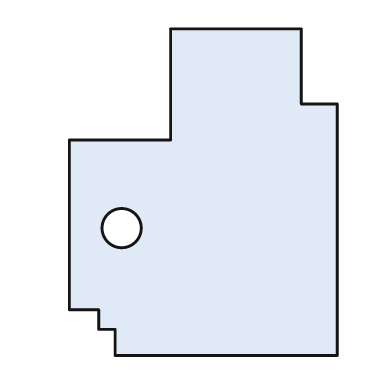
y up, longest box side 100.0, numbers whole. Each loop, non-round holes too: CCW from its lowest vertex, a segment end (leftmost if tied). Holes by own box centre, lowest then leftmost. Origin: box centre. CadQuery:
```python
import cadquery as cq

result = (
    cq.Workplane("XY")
    .moveTo(-27.0, -50.0)
    .lineTo(41.0, -50.0)
    .lineTo(41.0, 27.0)
    .lineTo(30.0, 27.0)
    .lineTo(30.0, 50.0)
    .lineTo(-10.0, 50.0)
    .lineTo(-10.0, 16.0)
    .lineTo(-41.0, 16.0)
    .lineTo(-41.0, -36.0)
    .lineTo(-32.0, -36.0)
    .lineTo(-32.0, -42.0)
    .lineTo(-27.0, -42.0)
    .close()
    .moveTo(-25.0, -11.0)
    .circle(6.0)
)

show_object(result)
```